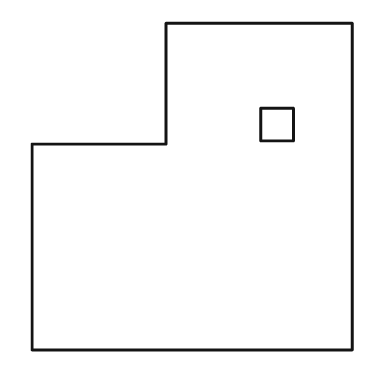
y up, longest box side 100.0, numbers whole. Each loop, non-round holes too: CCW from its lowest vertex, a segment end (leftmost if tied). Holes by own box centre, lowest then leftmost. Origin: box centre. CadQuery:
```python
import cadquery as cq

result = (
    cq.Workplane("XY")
    .moveTo(-49.0, -50.0)
    .lineTo(49.0, -50.0)
    .lineTo(49.0, 50.0)
    .lineTo(-8.0, 50.0)
    .lineTo(-8.0, 13.0)
    .lineTo(-49.0, 13.0)
    .close()
    .moveTo(21.0, 14.0)
    .lineTo(31.0, 14.0)
    .lineTo(31.0, 24.0)
    .lineTo(21.0, 24.0)
    .close()
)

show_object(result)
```